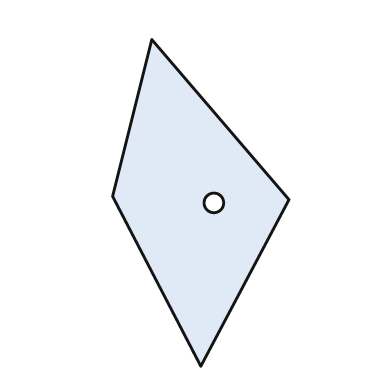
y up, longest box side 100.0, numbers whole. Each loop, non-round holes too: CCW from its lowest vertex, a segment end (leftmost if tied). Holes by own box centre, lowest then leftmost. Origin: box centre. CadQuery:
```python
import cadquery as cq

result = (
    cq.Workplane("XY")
    .moveTo(0.0, -50.0)
    .lineTo(27.0, 1.0)
    .lineTo(-15.0, 50.0)
    .lineTo(-27.0, 2.0)
    .close()
    .moveTo(4.0, 0.0)
    .circle(3.0)
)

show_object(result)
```